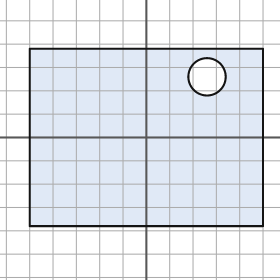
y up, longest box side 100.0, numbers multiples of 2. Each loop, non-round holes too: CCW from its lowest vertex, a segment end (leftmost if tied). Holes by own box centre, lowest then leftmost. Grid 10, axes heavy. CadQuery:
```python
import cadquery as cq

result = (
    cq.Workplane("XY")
    .moveTo(-50.0, -38.0)
    .lineTo(50.0, -38.0)
    .lineTo(50.0, 38.0)
    .lineTo(-50.0, 38.0)
    .close()
    .moveTo(26.0, 26.0)
    .circle(8.0)
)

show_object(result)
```